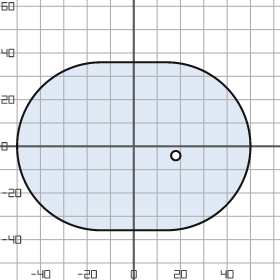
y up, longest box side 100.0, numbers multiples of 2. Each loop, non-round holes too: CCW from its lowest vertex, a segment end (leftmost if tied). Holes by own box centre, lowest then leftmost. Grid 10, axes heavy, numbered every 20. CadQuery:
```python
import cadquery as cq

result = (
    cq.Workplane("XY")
    .moveTo(-14.0, -36.0)
    .lineTo(14.0, -36.0)
    .threePointArc((50.0, 0.0), (14.0, 36.0))
    .lineTo(-14.0, 36.0)
    .threePointArc((-50.0, 0.0), (-14.0, -36.0))
    .close()
    .moveTo(18.0, -4.0)
    .circle(2.0)
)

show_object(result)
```